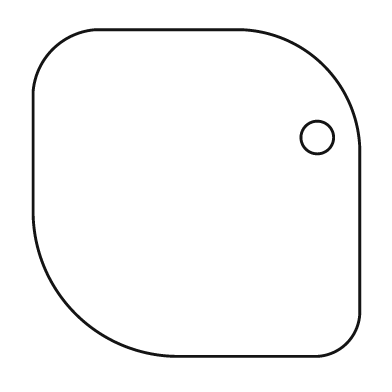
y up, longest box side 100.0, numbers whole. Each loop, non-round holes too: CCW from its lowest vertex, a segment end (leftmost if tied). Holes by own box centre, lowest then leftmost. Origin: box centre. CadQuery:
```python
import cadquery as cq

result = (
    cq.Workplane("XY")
    .moveTo(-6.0, -50.0)
    .lineTo(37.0, -50.0)
    .threePointArc((46.0, -46.0), (50.0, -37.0))
    .lineTo(50.0, 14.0)
    .threePointArc((39.0, 39.0), (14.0, 50.0))
    .lineTo(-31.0, 50.0)
    .threePointArc((-44.0, 44.0), (-50.0, 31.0))
    .lineTo(-50.0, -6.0)
    .threePointArc((-37.0, -37.0), (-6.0, -50.0))
    .close()
    .moveTo(37.0, 17.0)
    .circle(5.0)
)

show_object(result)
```